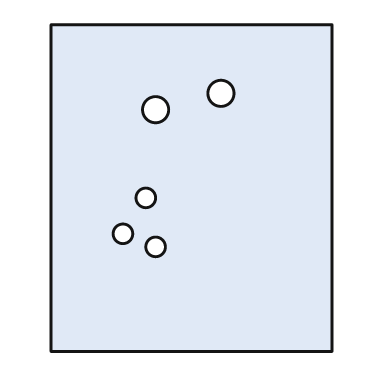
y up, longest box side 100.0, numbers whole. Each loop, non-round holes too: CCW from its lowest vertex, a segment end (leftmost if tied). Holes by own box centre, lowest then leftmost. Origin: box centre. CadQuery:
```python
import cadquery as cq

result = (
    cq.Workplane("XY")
    .moveTo(-43.0, -50.0)
    .lineTo(43.0, -50.0)
    .lineTo(43.0, 50.0)
    .lineTo(-43.0, 50.0)
    .close()
    .moveTo(-11.0, -18.0)
    .circle(3.0)
    .moveTo(-21.0, -14.0)
    .circle(3.0)
    .moveTo(-14.0, -3.0)
    .circle(3.0)
    .moveTo(-11.0, 24.0)
    .circle(4.0)
    .moveTo(9.0, 29.0)
    .circle(4.0)
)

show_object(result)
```